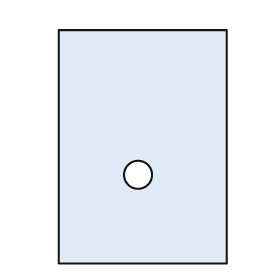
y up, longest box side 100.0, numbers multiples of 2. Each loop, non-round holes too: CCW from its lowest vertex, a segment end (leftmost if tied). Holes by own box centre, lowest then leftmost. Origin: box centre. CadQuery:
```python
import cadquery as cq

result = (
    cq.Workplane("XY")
    .moveTo(-36.0, -50.0)
    .lineTo(36.0, -50.0)
    .lineTo(36.0, 50.0)
    .lineTo(-36.0, 50.0)
    .close()
    .moveTo(-2.0, -12.0)
    .circle(6.0)
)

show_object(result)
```